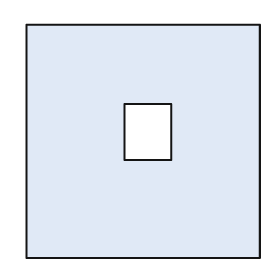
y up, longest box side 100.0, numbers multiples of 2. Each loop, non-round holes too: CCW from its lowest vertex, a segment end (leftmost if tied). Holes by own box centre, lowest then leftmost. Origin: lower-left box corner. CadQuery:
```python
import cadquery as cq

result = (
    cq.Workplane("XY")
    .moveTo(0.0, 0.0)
    .lineTo(100.0, 0.0)
    .lineTo(100.0, 100.0)
    .lineTo(0.0, 100.0)
    .close()
    .moveTo(42.0, 42.0)
    .lineTo(62.0, 42.0)
    .lineTo(62.0, 66.0)
    .lineTo(42.0, 66.0)
    .close()
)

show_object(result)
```